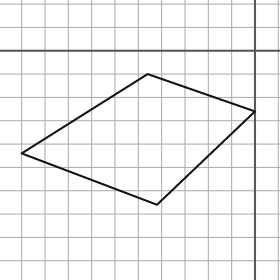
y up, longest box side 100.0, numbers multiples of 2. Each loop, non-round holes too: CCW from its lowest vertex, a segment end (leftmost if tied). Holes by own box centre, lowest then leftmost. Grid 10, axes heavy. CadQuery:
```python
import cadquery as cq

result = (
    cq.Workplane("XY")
    .moveTo(-42.0, -66.0)
    .lineTo(0.0, -26.0)
    .lineTo(-46.0, -10.0)
    .lineTo(-100.0, -44.0)
    .close()
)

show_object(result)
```